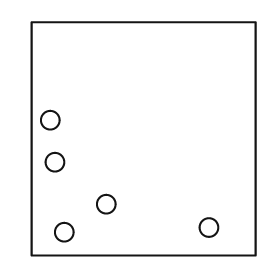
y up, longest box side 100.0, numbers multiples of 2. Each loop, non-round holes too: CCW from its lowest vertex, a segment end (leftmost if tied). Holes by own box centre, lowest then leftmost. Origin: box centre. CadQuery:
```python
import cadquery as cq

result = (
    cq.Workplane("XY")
    .moveTo(-48.0, -50.0)
    .lineTo(48.0, -50.0)
    .lineTo(48.0, 50.0)
    .lineTo(-48.0, 50.0)
    .close()
    .moveTo(-34.0, -40.0)
    .circle(4.0)
    .moveTo(28.0, -38.0)
    .circle(4.0)
    .moveTo(-16.0, -28.0)
    .circle(4.0)
    .moveTo(-38.0, -10.0)
    .circle(4.0)
    .moveTo(-40.0, 8.0)
    .circle(4.0)
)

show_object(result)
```